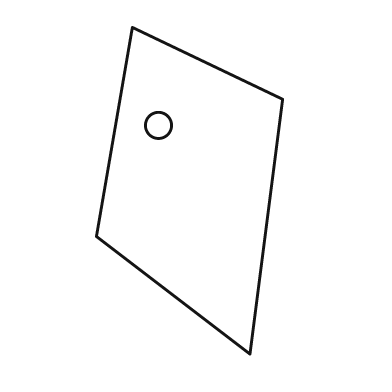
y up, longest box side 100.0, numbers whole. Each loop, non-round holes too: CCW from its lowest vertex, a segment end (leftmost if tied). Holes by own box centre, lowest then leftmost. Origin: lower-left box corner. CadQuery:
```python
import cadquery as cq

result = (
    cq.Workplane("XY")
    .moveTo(47.0, 0.0)
    .lineTo(57.0, 78.0)
    .lineTo(11.0, 100.0)
    .lineTo(0.0, 36.0)
    .close()
    .moveTo(19.0, 70.0)
    .circle(4.0)
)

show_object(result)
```